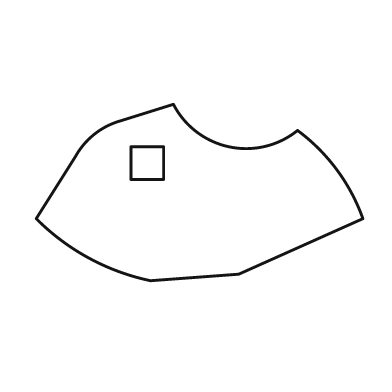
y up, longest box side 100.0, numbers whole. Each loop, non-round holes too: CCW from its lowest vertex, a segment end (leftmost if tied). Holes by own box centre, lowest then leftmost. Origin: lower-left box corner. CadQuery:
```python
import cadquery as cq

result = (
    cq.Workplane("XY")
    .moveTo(35.0, 0.0)
    .lineTo(62.0, 2.0)
    .lineTo(100.0, 19.0)
    .threePointArc((92.0, 34.0), (80.0, 46.0))
    .threePointArc((59.0, 41.0), (42.0, 54.0))
    .lineTo(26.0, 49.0)
    .threePointArc((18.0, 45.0), (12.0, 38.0))
    .lineTo(0.0, 19.0)
    .threePointArc((16.0, 7.0), (35.0, 0.0))
    .close()
    .moveTo(29.0, 31.0)
    .lineTo(39.0, 31.0)
    .lineTo(39.0, 41.0)
    .lineTo(29.0, 41.0)
    .close()
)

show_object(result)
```